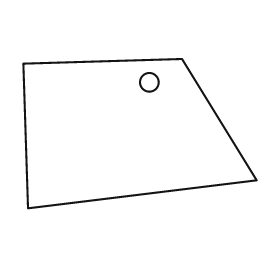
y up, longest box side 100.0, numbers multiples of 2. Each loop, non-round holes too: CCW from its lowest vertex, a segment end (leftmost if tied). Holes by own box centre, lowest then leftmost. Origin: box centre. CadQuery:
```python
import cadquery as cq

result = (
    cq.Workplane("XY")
    .moveTo(-48.0, -32.0)
    .lineTo(50.0, -20.0)
    .lineTo(18.0, 32.0)
    .lineTo(-50.0, 30.0)
    .close()
    .moveTo(4.0, 22.0)
    .circle(4.0)
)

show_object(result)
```